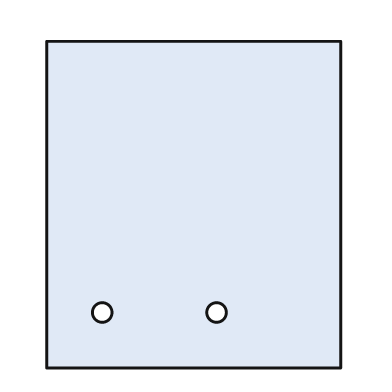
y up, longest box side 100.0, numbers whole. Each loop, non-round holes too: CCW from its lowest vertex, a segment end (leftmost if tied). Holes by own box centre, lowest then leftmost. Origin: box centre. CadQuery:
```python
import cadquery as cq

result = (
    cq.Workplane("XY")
    .moveTo(-45.0, -50.0)
    .lineTo(45.0, -50.0)
    .lineTo(45.0, 50.0)
    .lineTo(-45.0, 50.0)
    .close()
    .moveTo(-28.0, -33.0)
    .circle(3.0)
    .moveTo(7.0, -33.0)
    .circle(3.0)
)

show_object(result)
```